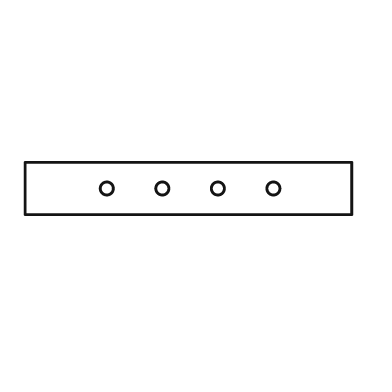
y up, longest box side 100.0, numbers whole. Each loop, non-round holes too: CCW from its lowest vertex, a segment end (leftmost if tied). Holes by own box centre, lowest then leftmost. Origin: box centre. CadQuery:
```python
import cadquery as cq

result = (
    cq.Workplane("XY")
    .moveTo(-50.0, -8.0)
    .lineTo(50.0, -8.0)
    .lineTo(50.0, 8.0)
    .lineTo(-50.0, 8.0)
    .close()
    .moveTo(-25.0, 0.0)
    .circle(2.0)
    .moveTo(-8.0, 0.0)
    .circle(2.0)
    .moveTo(9.0, 0.0)
    .circle(2.0)
    .moveTo(26.0, 0.0)
    .circle(2.0)
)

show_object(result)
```